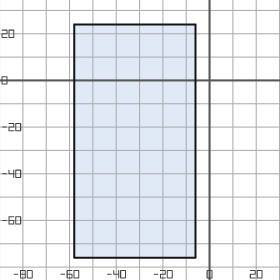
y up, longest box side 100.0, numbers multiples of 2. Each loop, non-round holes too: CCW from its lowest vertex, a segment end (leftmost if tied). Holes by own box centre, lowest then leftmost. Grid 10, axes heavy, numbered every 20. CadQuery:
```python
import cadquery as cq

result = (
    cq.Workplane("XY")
    .moveTo(-58.0, -76.0)
    .lineTo(-6.0, -76.0)
    .lineTo(-6.0, 24.0)
    .lineTo(-58.0, 24.0)
    .close()
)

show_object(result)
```